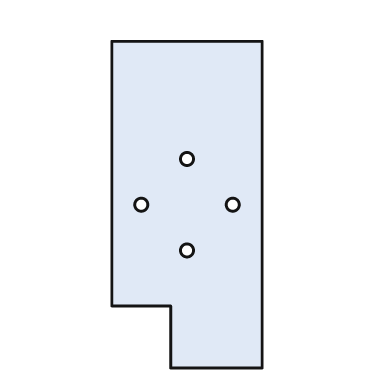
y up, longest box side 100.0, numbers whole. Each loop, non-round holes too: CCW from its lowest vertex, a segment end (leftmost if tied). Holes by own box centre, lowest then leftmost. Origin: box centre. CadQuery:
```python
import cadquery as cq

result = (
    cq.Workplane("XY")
    .moveTo(-5.0, -50.0)
    .lineTo(23.0, -50.0)
    .lineTo(23.0, 50.0)
    .lineTo(-23.0, 50.0)
    .lineTo(-23.0, -31.0)
    .lineTo(-5.0, -31.0)
    .close()
    .moveTo(0.0, -14.0)
    .circle(2.0)
    .moveTo(-14.0, 0.0)
    .circle(2.0)
    .moveTo(14.0, 0.0)
    .circle(2.0)
    .moveTo(0.0, 14.0)
    .circle(2.0)
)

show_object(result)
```